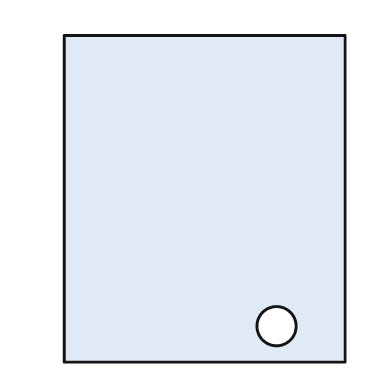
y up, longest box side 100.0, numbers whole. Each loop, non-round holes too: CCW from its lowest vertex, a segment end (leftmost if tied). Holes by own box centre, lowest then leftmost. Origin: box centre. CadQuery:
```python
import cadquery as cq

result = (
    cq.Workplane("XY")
    .moveTo(-43.0, -50.0)
    .lineTo(43.0, -50.0)
    .lineTo(43.0, 50.0)
    .lineTo(-43.0, 50.0)
    .close()
    .moveTo(22.0, -39.0)
    .circle(6.0)
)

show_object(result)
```